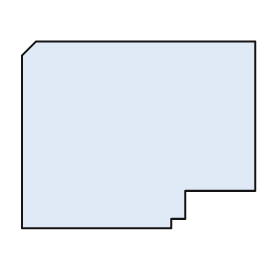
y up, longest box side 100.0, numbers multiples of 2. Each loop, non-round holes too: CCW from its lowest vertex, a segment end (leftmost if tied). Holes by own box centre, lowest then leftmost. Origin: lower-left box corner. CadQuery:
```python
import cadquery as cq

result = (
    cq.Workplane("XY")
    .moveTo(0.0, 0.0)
    .lineTo(64.0, 0.0)
    .lineTo(64.0, 4.0)
    .lineTo(70.0, 4.0)
    .lineTo(70.0, 16.0)
    .lineTo(100.0, 16.0)
    .lineTo(100.0, 80.0)
    .lineTo(6.0, 80.0)
    .lineTo(0.0, 74.0)
    .close()
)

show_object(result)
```